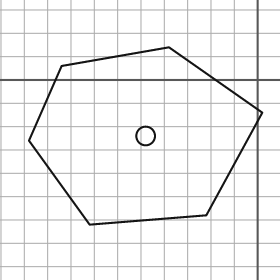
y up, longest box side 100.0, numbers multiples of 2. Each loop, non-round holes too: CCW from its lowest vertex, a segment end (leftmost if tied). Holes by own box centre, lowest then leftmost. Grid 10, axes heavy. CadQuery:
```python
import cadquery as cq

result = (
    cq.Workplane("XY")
    .moveTo(-72.0, -62.0)
    .lineTo(-22.0, -58.0)
    .lineTo(2.0, -14.0)
    .lineTo(-38.0, 14.0)
    .lineTo(-84.0, 6.0)
    .lineTo(-98.0, -26.0)
    .close()
    .moveTo(-48.0, -24.0)
    .circle(4.0)
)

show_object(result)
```